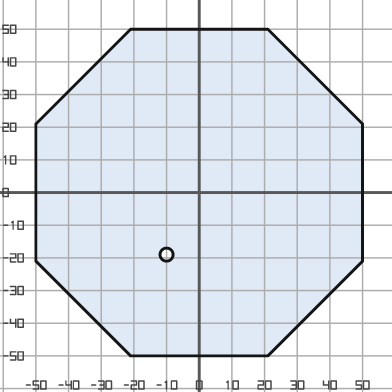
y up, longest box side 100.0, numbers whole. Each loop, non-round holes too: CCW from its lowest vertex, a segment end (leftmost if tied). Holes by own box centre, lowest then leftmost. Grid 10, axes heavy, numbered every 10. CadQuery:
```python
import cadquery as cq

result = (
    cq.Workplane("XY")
    .moveTo(-21.0, -50.0)
    .lineTo(21.0, -50.0)
    .lineTo(50.0, -21.0)
    .lineTo(50.0, 21.0)
    .lineTo(21.0, 50.0)
    .lineTo(-21.0, 50.0)
    .lineTo(-50.0, 21.0)
    .lineTo(-50.0, -21.0)
    .close()
    .moveTo(-10.0, -19.0)
    .circle(2.0)
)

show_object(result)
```